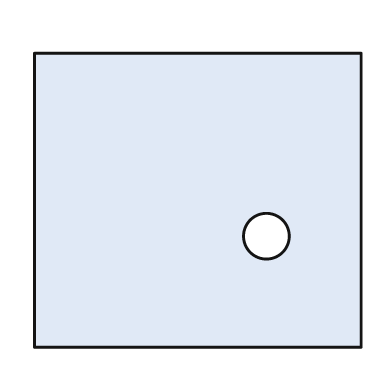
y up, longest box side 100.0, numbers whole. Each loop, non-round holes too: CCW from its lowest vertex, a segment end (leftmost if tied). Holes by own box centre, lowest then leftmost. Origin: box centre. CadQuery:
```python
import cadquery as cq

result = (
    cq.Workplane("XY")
    .moveTo(-50.0, -45.0)
    .lineTo(50.0, -45.0)
    .lineTo(50.0, 45.0)
    .lineTo(-50.0, 45.0)
    .close()
    .moveTo(21.0, -11.0)
    .circle(7.0)
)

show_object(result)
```